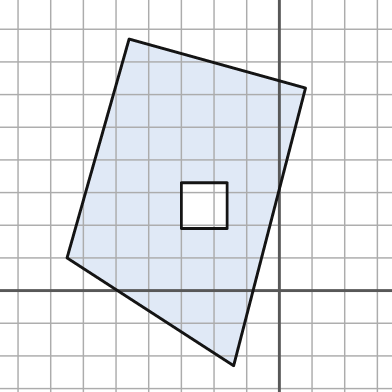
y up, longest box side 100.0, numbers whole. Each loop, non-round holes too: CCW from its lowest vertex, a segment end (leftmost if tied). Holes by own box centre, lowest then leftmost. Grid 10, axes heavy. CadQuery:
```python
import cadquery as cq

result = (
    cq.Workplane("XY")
    .moveTo(-14.0, -23.0)
    .lineTo(8.0, 62.0)
    .lineTo(-46.0, 77.0)
    .lineTo(-65.0, 10.0)
    .close()
    .moveTo(-30.0, 19.0)
    .lineTo(-16.0, 19.0)
    .lineTo(-16.0, 33.0)
    .lineTo(-30.0, 33.0)
    .close()
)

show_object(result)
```